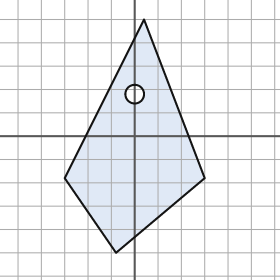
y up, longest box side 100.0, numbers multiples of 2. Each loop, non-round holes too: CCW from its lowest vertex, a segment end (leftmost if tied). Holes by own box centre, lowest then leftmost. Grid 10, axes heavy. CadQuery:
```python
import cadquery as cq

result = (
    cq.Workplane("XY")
    .moveTo(-8.0, -50.0)
    .lineTo(30.0, -18.0)
    .lineTo(4.0, 50.0)
    .lineTo(-30.0, -18.0)
    .close()
    .moveTo(0.0, 18.0)
    .circle(4.0)
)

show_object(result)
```